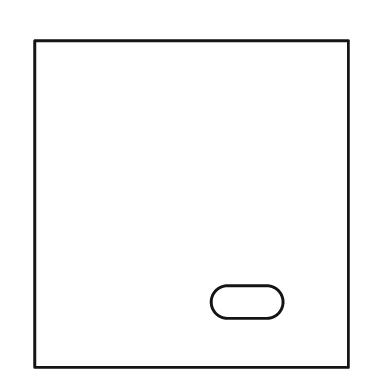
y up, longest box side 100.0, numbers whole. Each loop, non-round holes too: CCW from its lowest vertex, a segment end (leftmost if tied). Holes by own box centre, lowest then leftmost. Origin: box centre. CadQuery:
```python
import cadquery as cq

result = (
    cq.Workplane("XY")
    .moveTo(-48.0, -50.0)
    .lineTo(48.0, -50.0)
    .lineTo(48.0, 50.0)
    .lineTo(-48.0, 50.0)
    .close()
    .moveTo(11.0, -35.0)
    .lineTo(23.0, -35.0)
    .threePointArc((28.0, -30.0), (23.0, -25.0))
    .lineTo(11.0, -25.0)
    .threePointArc((6.0, -30.0), (11.0, -35.0))
    .close()
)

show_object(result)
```